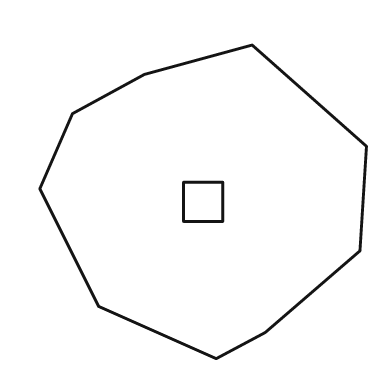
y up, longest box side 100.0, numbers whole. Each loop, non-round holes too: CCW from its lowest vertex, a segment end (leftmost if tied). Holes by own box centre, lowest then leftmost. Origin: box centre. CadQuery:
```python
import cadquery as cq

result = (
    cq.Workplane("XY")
    .moveTo(4.0, -48.0)
    .lineTo(19.0, -40.0)
    .lineTo(48.0, -15.0)
    .lineTo(50.0, 17.0)
    .lineTo(15.0, 48.0)
    .lineTo(-18.0, 39.0)
    .lineTo(-40.0, 27.0)
    .lineTo(-50.0, 4.0)
    .lineTo(-32.0, -32.0)
    .close()
    .moveTo(-6.0, -6.0)
    .lineTo(6.0, -6.0)
    .lineTo(6.0, 6.0)
    .lineTo(-6.0, 6.0)
    .close()
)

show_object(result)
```